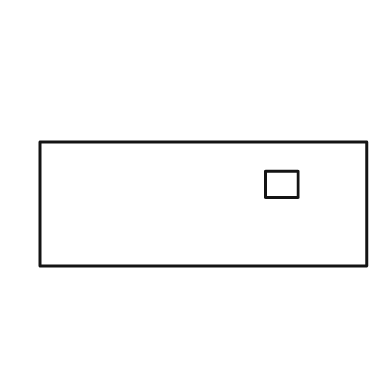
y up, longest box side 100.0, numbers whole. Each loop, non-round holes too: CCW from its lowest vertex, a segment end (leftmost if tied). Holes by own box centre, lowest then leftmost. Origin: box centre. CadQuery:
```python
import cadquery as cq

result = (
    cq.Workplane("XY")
    .moveTo(-50.0, -19.0)
    .lineTo(50.0, -19.0)
    .lineTo(50.0, 19.0)
    .lineTo(-50.0, 19.0)
    .close()
    .moveTo(19.0, 2.0)
    .lineTo(29.0, 2.0)
    .lineTo(29.0, 10.0)
    .lineTo(19.0, 10.0)
    .close()
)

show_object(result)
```